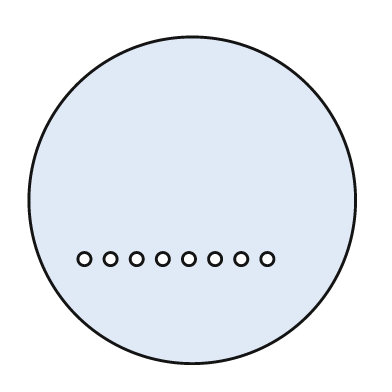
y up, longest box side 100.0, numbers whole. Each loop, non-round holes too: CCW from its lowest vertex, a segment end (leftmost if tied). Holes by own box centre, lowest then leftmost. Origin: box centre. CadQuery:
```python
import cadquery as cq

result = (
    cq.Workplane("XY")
    .moveTo(0.0, 0.0)
    .circle(50.0)
    .moveTo(-33.0, -18.0)
    .circle(2.0)
    .moveTo(-25.0, -18.0)
    .circle(2.0)
    .moveTo(-17.0, -18.0)
    .circle(2.0)
    .moveTo(-9.0, -18.0)
    .circle(2.0)
    .moveTo(-1.0, -18.0)
    .circle(2.0)
    .moveTo(7.0, -18.0)
    .circle(2.0)
    .moveTo(15.0, -18.0)
    .circle(2.0)
    .moveTo(23.0, -18.0)
    .circle(2.0)
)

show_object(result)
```